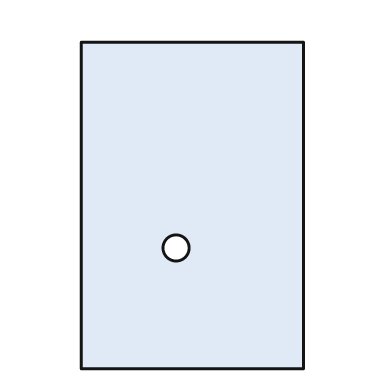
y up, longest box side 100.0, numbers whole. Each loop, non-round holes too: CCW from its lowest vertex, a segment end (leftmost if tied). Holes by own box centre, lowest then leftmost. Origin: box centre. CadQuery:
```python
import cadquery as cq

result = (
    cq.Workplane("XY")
    .moveTo(-34.0, -50.0)
    .lineTo(34.0, -50.0)
    .lineTo(34.0, 50.0)
    .lineTo(-34.0, 50.0)
    .close()
    .moveTo(-5.0, -13.0)
    .circle(4.0)
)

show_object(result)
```